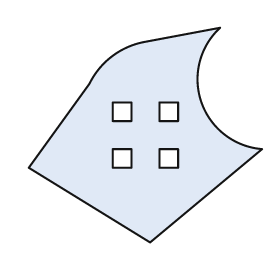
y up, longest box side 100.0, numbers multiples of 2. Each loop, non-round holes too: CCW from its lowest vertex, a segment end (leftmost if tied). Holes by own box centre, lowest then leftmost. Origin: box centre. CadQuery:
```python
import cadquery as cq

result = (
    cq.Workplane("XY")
    .moveTo(2.0, -46.0)
    .lineTo(50.0, -6.0)
    .threePointArc((24.0, 14.0), (32.0, 46.0))
    .lineTo(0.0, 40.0)
    .threePointArc((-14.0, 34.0), (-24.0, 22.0))
    .lineTo(-50.0, -14.0)
    .close()
    .moveTo(-14.0, -14.0)
    .lineTo(-6.0, -14.0)
    .lineTo(-6.0, -6.0)
    .lineTo(-14.0, -6.0)
    .close()
    .moveTo(6.0, -14.0)
    .lineTo(14.0, -14.0)
    .lineTo(14.0, -6.0)
    .lineTo(6.0, -6.0)
    .close()
    .moveTo(-14.0, 6.0)
    .lineTo(-6.0, 6.0)
    .lineTo(-6.0, 14.0)
    .lineTo(-14.0, 14.0)
    .close()
    .moveTo(6.0, 6.0)
    .lineTo(14.0, 6.0)
    .lineTo(14.0, 14.0)
    .lineTo(6.0, 14.0)
    .close()
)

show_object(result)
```